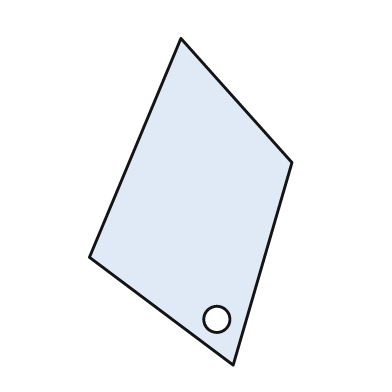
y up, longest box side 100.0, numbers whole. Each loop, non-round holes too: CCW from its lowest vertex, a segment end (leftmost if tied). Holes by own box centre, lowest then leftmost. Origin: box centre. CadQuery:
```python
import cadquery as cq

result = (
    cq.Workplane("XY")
    .moveTo(13.0, -50.0)
    .lineTo(31.0, 12.0)
    .lineTo(-3.0, 50.0)
    .lineTo(-31.0, -17.0)
    .close()
    .moveTo(8.0, -36.0)
    .circle(4.0)
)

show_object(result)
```